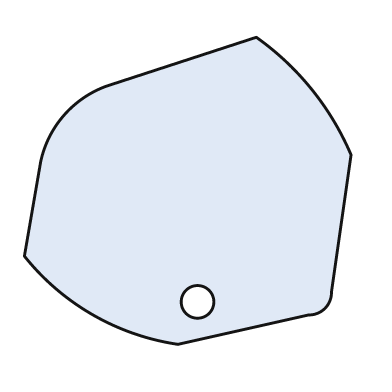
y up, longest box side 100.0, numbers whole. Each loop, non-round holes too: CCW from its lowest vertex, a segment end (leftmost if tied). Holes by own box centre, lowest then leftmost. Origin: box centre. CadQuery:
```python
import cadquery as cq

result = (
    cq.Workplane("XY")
    .moveTo(-3.0, -47.0)
    .lineTo(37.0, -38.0)
    .threePointArc((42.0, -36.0), (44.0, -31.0))
    .lineTo(50.0, 11.0)
    .threePointArc((38.0, 31.0), (21.0, 47.0))
    .lineTo(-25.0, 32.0)
    .threePointArc((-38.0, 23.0), (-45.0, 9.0))
    .lineTo(-50.0, -20.0)
    .threePointArc((-29.0, -38.0), (-3.0, -47.0))
    .close()
    .moveTo(3.0, -34.0)
    .circle(5.0)
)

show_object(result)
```